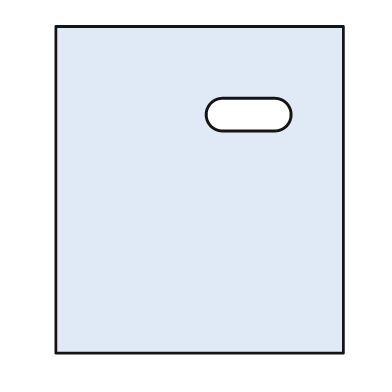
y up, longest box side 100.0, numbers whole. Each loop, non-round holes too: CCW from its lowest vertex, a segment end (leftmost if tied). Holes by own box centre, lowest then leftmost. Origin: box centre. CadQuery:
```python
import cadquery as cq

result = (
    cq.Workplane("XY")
    .moveTo(-44.0, -50.0)
    .lineTo(44.0, -50.0)
    .lineTo(44.0, 50.0)
    .lineTo(-44.0, 50.0)
    .close()
    .moveTo(7.0, 18.0)
    .lineTo(23.0, 18.0)
    .threePointArc((28.0, 23.0), (23.0, 28.0))
    .lineTo(7.0, 28.0)
    .threePointArc((2.0, 23.0), (7.0, 18.0))
    .close()
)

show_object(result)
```